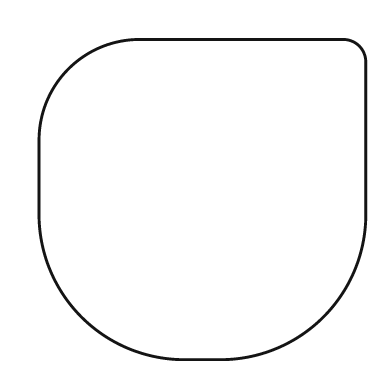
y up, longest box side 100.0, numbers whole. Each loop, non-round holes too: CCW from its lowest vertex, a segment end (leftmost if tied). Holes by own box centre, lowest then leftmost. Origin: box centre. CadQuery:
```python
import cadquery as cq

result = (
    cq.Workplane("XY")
    .moveTo(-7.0, -49.0)
    .lineTo(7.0, -49.0)
    .threePointArc((37.0, -36.0), (50.0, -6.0))
    .lineTo(50.0, 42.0)
    .threePointArc((48.0, 47.0), (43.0, 49.0))
    .lineTo(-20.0, 49.0)
    .threePointArc((-41.0, 40.0), (-50.0, 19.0))
    .lineTo(-50.0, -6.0)
    .threePointArc((-37.0, -36.0), (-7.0, -49.0))
    .close()
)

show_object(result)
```